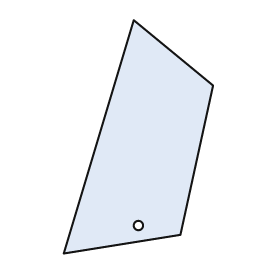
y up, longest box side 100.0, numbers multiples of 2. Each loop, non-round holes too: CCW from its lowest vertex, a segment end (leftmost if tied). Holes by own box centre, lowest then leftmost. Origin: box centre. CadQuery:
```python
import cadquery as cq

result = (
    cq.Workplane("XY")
    .moveTo(-32.0, -50.0)
    .lineTo(18.0, -42.0)
    .lineTo(32.0, 22.0)
    .lineTo(-2.0, 50.0)
    .close()
    .moveTo(0.0, -38.0)
    .circle(2.0)
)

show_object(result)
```